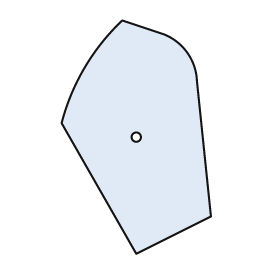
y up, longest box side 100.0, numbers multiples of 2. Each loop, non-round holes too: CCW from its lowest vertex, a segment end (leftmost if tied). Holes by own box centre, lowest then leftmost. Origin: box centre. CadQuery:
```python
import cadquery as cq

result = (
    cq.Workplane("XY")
    .moveTo(0.0, -50.0)
    .lineTo(32.0, -34.0)
    .lineTo(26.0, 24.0)
    .threePointArc((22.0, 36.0), (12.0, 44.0))
    .lineTo(-6.0, 50.0)
    .threePointArc((-22.0, 30.0), (-32.0, 6.0))
    .close()
    .moveTo(0.0, 0.0)
    .circle(2.0)
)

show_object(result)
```